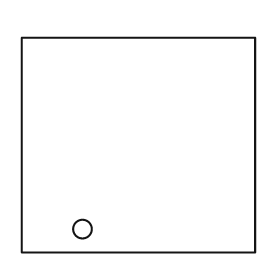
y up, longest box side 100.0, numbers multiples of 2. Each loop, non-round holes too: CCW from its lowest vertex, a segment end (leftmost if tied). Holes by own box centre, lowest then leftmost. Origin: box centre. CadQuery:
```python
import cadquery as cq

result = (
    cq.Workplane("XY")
    .moveTo(-50.0, -46.0)
    .lineTo(50.0, -46.0)
    .lineTo(50.0, 46.0)
    .lineTo(-50.0, 46.0)
    .close()
    .moveTo(-24.0, -36.0)
    .circle(4.0)
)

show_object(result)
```